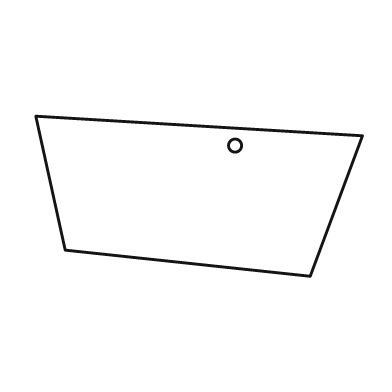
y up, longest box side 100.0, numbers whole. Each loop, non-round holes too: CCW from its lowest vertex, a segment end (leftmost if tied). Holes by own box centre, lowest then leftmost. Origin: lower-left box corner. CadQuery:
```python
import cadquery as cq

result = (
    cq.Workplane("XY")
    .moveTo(84.0, 0.0)
    .lineTo(100.0, 43.0)
    .lineTo(0.0, 49.0)
    .lineTo(9.0, 8.0)
    .close()
    .moveTo(61.0, 40.0)
    .circle(2.0)
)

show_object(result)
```